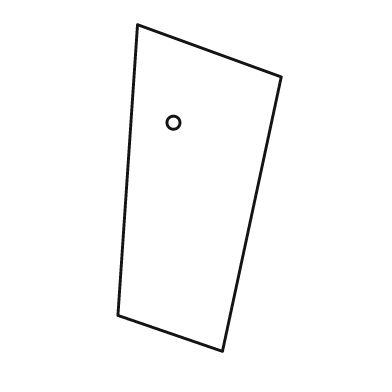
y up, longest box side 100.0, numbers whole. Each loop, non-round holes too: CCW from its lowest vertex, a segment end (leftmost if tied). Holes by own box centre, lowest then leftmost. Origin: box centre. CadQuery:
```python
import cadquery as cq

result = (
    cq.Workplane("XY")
    .moveTo(7.0, -50.0)
    .lineTo(25.0, 34.0)
    .lineTo(-19.0, 50.0)
    .lineTo(-25.0, -39.0)
    .close()
    .moveTo(-8.0, 20.0)
    .circle(2.0)
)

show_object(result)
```